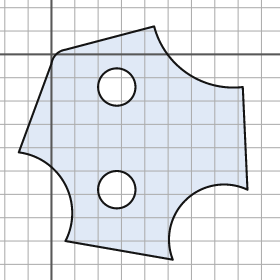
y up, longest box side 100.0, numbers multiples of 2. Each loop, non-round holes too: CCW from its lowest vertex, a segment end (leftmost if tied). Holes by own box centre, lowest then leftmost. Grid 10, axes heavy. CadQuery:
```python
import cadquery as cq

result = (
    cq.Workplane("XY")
    .moveTo(52.0, -88.0)
    .threePointArc((58.0, -62.0), (84.0, -58.0))
    .lineTo(82.0, -14.0)
    .threePointArc((58.0, -8.0), (44.0, 12.0))
    .lineTo(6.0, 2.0)
    .threePointArc((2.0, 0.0), (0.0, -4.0))
    .lineTo(-14.0, -42.0)
    .threePointArc((6.0, -56.0), (6.0, -80.0))
    .close()
    .moveTo(28.0, -58.0)
    .circle(8.0)
    .moveTo(28.0, -14.0)
    .circle(8.0)
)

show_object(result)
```